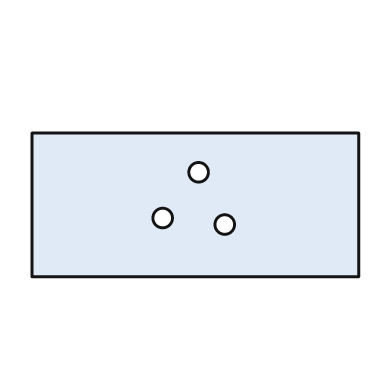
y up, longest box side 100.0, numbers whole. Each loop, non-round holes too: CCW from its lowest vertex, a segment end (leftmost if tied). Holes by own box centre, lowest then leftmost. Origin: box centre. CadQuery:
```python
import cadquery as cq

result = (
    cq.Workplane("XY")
    .moveTo(-50.0, -22.0)
    .lineTo(50.0, -22.0)
    .lineTo(50.0, 22.0)
    .lineTo(-50.0, 22.0)
    .close()
    .moveTo(9.0, -6.0)
    .circle(3.0)
    .moveTo(-10.0, -4.0)
    .circle(3.0)
    .moveTo(1.0, 10.0)
    .circle(3.0)
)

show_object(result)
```